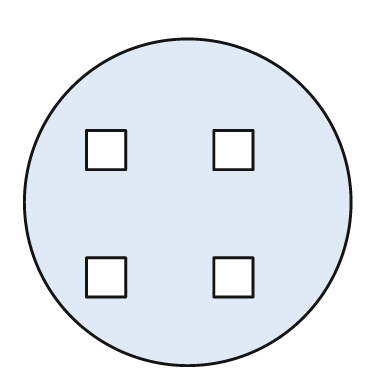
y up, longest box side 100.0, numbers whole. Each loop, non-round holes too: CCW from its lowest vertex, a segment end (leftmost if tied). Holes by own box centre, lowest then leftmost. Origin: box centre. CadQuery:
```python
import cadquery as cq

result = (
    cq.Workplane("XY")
    .moveTo(0.0, 0.0)
    .circle(50.0)
    .moveTo(-31.0, -29.0)
    .lineTo(-19.0, -29.0)
    .lineTo(-19.0, -17.0)
    .lineTo(-31.0, -17.0)
    .close()
    .moveTo(8.0, -29.0)
    .lineTo(20.0, -29.0)
    .lineTo(20.0, -17.0)
    .lineTo(8.0, -17.0)
    .close()
    .moveTo(-31.0, 10.0)
    .lineTo(-19.0, 10.0)
    .lineTo(-19.0, 22.0)
    .lineTo(-31.0, 22.0)
    .close()
    .moveTo(8.0, 10.0)
    .lineTo(20.0, 10.0)
    .lineTo(20.0, 22.0)
    .lineTo(8.0, 22.0)
    .close()
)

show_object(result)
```